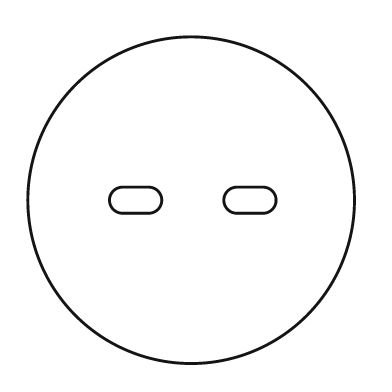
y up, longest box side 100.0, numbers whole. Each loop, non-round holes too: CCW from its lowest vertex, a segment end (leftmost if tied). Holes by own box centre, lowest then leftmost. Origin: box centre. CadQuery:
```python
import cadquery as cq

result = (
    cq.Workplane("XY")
    .moveTo(0.0, 0.0)
    .circle(50.0)
    .moveTo(-21.0, -4.0)
    .lineTo(-13.0, -4.0)
    .threePointArc((-9.0, 0.0), (-13.0, 4.0))
    .lineTo(-21.0, 4.0)
    .threePointArc((-25.0, 0.0), (-21.0, -4.0))
    .close()
    .moveTo(14.0, -4.0)
    .lineTo(22.0, -4.0)
    .threePointArc((26.0, 0.0), (22.0, 4.0))
    .lineTo(14.0, 4.0)
    .threePointArc((10.0, 0.0), (14.0, -4.0))
    .close()
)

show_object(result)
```